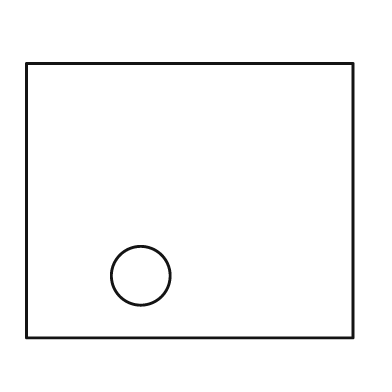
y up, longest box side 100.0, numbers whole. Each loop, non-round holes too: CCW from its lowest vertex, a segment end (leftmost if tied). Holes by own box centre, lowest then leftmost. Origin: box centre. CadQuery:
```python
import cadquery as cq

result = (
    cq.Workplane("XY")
    .moveTo(-50.0, -42.0)
    .lineTo(50.0, -42.0)
    .lineTo(50.0, 42.0)
    .lineTo(-50.0, 42.0)
    .close()
    .moveTo(-15.0, -23.0)
    .circle(9.0)
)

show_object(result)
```